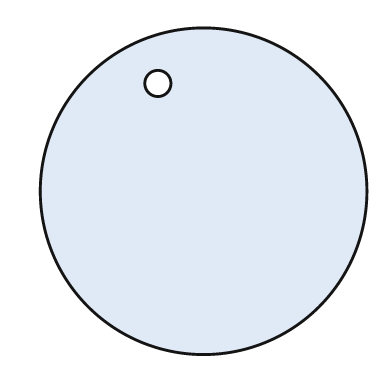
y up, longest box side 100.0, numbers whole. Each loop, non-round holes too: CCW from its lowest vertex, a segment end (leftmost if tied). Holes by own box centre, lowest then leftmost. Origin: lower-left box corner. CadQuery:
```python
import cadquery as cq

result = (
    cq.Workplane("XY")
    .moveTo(50.0, 50.0)
    .circle(50.0)
    .moveTo(36.0, 83.0)
    .circle(4.0)
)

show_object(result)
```